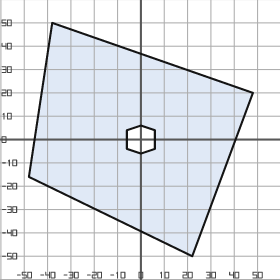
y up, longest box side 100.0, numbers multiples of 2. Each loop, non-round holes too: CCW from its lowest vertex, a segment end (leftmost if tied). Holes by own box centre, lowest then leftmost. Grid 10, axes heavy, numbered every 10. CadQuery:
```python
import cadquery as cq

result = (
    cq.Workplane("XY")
    .moveTo(22.0, -50.0)
    .lineTo(48.0, 20.0)
    .lineTo(-38.0, 50.0)
    .lineTo(-48.0, -16.0)
    .close()
    .moveTo(0.0, -6.0)
    .lineTo(6.0, -4.0)
    .lineTo(6.0, 4.0)
    .lineTo(0.0, 6.0)
    .lineTo(-6.0, 4.0)
    .lineTo(-6.0, -4.0)
    .close()
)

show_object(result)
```